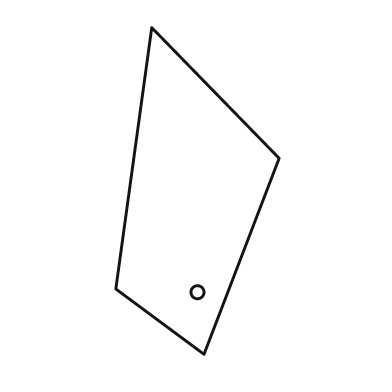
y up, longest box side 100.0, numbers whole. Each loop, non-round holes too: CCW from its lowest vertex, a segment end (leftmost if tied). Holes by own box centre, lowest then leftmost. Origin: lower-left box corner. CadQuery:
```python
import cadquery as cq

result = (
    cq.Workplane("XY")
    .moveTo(27.0, 0.0)
    .lineTo(50.0, 60.0)
    .lineTo(11.0, 100.0)
    .lineTo(0.0, 20.0)
    .close()
    .moveTo(25.0, 19.0)
    .circle(2.0)
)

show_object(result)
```